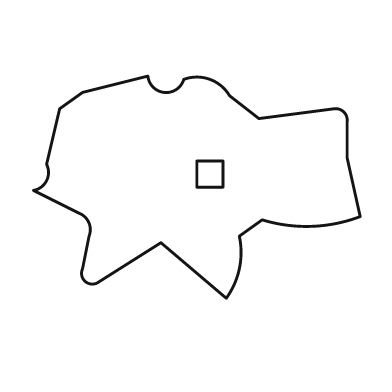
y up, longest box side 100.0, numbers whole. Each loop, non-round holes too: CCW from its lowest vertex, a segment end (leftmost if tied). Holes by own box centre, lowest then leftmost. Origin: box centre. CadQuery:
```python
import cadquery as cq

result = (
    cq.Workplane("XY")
    .moveTo(9.0, -34.0)
    .threePointArc((13.0, -25.0), (13.0, -15.0))
    .lineTo(20.0, -10.0)
    .threePointArc((35.0, -12.0), (50.0, -9.0))
    .lineTo(46.0, 9.0)
    .lineTo(46.0, 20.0)
    .threePointArc((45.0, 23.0), (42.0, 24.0))
    .lineTo(19.0, 21.0)
    .lineTo(10.0, 28.0)
    .threePointArc((4.0, 33.0), (-4.0, 33.0))
    .threePointArc((-10.0, 29.0), (-15.0, 34.0))
    .lineTo(-35.0, 29.0)
    .lineTo(-42.0, 24.0)
    .lineTo(-46.0, 7.0)
    .threePointArc((-46.0, 2.0), (-50.0, -1.0))
    .lineTo(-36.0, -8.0)
    .threePointArc((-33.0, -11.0), (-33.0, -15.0))
    .lineTo(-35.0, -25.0)
    .threePointArc((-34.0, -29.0), (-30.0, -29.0))
    .lineTo(-11.0, -17.0)
    .close()
    .moveTo(0.0, 0.0)
    .lineTo(8.0, 0.0)
    .lineTo(8.0, 8.0)
    .lineTo(0.0, 8.0)
    .close()
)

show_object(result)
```